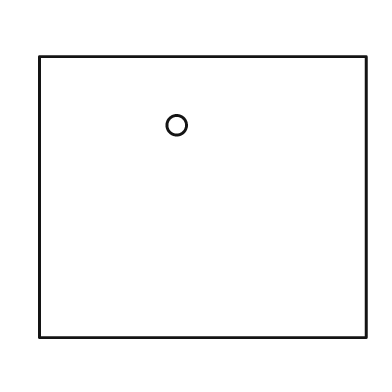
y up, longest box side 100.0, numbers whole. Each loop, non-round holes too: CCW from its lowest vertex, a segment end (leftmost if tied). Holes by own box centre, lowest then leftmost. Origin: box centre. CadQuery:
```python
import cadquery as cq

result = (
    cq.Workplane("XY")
    .moveTo(-50.0, -43.0)
    .lineTo(50.0, -43.0)
    .lineTo(50.0, 43.0)
    .lineTo(-50.0, 43.0)
    .close()
    .moveTo(-8.0, 22.0)
    .circle(3.0)
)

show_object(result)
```